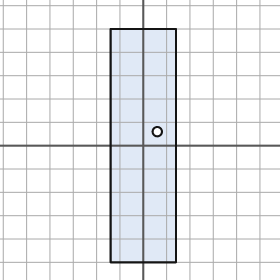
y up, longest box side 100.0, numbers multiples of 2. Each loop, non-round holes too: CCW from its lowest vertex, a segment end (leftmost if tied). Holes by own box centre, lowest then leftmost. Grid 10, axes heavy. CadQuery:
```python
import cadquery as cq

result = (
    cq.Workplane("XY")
    .moveTo(-14.0, -50.0)
    .lineTo(14.0, -50.0)
    .lineTo(14.0, 50.0)
    .lineTo(-14.0, 50.0)
    .close()
    .moveTo(6.0, 6.0)
    .circle(2.0)
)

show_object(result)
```